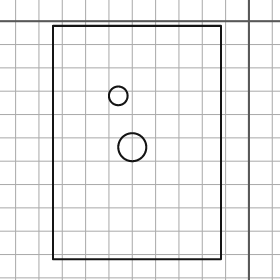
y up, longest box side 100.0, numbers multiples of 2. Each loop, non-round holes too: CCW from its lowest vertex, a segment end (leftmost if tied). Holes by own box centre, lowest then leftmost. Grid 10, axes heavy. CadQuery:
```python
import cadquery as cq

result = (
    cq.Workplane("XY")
    .moveTo(-84.0, -102.0)
    .lineTo(-12.0, -102.0)
    .lineTo(-12.0, -2.0)
    .lineTo(-84.0, -2.0)
    .close()
    .moveTo(-50.0, -54.0)
    .circle(6.0)
    .moveTo(-56.0, -32.0)
    .circle(4.0)
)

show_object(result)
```